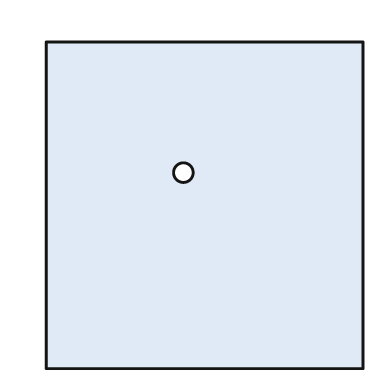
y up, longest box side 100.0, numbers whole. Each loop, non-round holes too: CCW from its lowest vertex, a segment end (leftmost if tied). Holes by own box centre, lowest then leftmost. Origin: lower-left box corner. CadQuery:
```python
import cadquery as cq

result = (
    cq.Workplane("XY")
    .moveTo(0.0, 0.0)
    .lineTo(97.0, 0.0)
    .lineTo(97.0, 100.0)
    .lineTo(0.0, 100.0)
    .close()
    .moveTo(42.0, 60.0)
    .circle(3.0)
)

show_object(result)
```